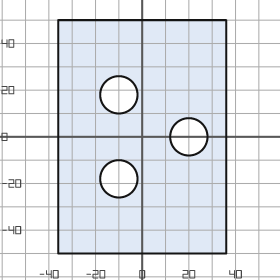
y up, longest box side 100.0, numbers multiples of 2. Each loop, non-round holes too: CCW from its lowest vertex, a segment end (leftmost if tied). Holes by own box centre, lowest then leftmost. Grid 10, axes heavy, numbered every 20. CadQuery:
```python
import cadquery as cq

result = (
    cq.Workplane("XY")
    .moveTo(-36.0, -50.0)
    .lineTo(36.0, -50.0)
    .lineTo(36.0, 50.0)
    .lineTo(-36.0, 50.0)
    .close()
    .moveTo(-10.0, -18.0)
    .circle(8.0)
    .moveTo(20.0, 0.0)
    .circle(8.0)
    .moveTo(-10.0, 18.0)
    .circle(8.0)
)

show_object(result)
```